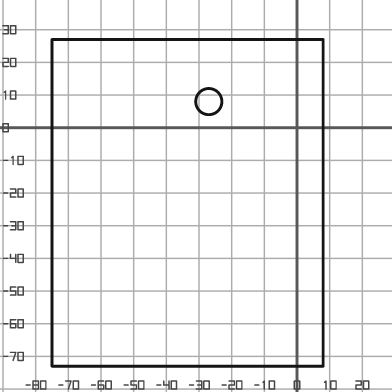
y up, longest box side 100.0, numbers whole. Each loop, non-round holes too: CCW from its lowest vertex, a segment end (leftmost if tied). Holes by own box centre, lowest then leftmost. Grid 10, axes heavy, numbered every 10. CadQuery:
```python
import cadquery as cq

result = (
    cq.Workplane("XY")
    .moveTo(-75.0, -73.0)
    .lineTo(8.0, -73.0)
    .lineTo(8.0, 27.0)
    .lineTo(-75.0, 27.0)
    .close()
    .moveTo(-27.0, 8.0)
    .circle(4.0)
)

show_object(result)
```